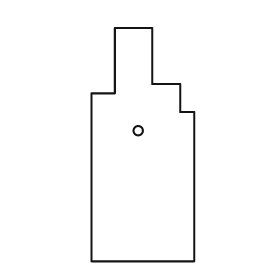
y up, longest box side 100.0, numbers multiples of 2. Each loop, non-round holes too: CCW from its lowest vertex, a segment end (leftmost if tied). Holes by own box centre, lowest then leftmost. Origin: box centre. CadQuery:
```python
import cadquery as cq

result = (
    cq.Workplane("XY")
    .moveTo(-22.0, -50.0)
    .lineTo(22.0, -50.0)
    .lineTo(22.0, 14.0)
    .lineTo(16.0, 14.0)
    .lineTo(16.0, 26.0)
    .lineTo(4.0, 26.0)
    .lineTo(4.0, 50.0)
    .lineTo(-12.0, 50.0)
    .lineTo(-12.0, 22.0)
    .lineTo(-22.0, 22.0)
    .close()
    .moveTo(-2.0, 6.0)
    .circle(2.0)
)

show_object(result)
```